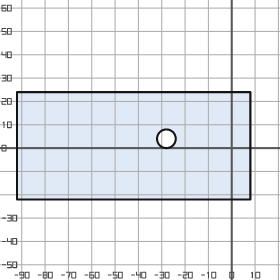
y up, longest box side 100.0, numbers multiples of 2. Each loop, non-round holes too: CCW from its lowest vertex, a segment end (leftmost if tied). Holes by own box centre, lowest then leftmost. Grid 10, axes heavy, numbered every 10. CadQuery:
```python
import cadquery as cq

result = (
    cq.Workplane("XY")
    .moveTo(-92.0, -22.0)
    .lineTo(8.0, -22.0)
    .lineTo(8.0, 24.0)
    .lineTo(-92.0, 24.0)
    .close()
    .moveTo(-28.0, 4.0)
    .circle(4.0)
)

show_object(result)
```